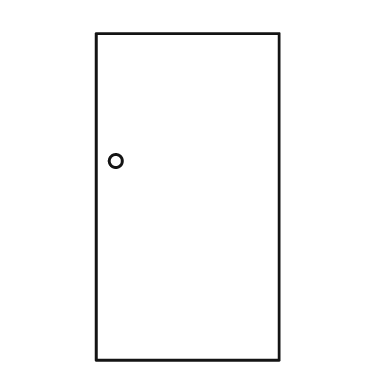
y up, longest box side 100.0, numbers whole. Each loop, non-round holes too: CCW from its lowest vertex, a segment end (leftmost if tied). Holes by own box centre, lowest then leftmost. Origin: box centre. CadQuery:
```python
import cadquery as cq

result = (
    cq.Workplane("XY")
    .moveTo(-28.0, -50.0)
    .lineTo(28.0, -50.0)
    .lineTo(28.0, 50.0)
    .lineTo(-28.0, 50.0)
    .close()
    .moveTo(-22.0, 11.0)
    .circle(2.0)
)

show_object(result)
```